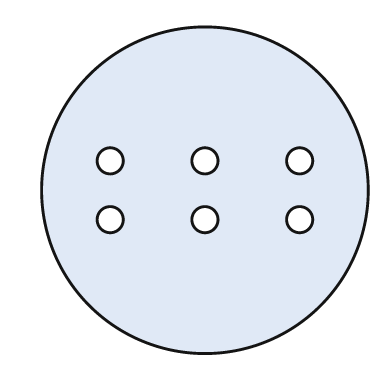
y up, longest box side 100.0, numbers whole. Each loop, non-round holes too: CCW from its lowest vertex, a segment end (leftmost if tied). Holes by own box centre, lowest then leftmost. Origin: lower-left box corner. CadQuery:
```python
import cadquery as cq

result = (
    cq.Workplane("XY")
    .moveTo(50.0, 50.0)
    .circle(50.0)
    .moveTo(21.0, 41.0)
    .circle(4.0)
    .moveTo(50.0, 41.0)
    .circle(4.0)
    .moveTo(79.0, 41.0)
    .circle(4.0)
    .moveTo(21.0, 59.0)
    .circle(4.0)
    .moveTo(50.0, 59.0)
    .circle(4.0)
    .moveTo(79.0, 59.0)
    .circle(4.0)
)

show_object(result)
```